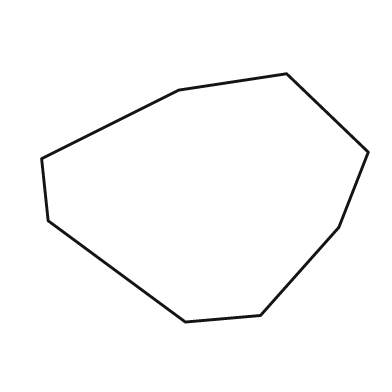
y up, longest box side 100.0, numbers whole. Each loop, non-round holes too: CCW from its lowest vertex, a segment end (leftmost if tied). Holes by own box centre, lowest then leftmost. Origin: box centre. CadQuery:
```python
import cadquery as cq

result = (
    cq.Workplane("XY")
    .moveTo(-6.0, -38.0)
    .lineTo(17.0, -36.0)
    .lineTo(41.0, -9.0)
    .lineTo(50.0, 14.0)
    .lineTo(25.0, 38.0)
    .lineTo(-8.0, 33.0)
    .lineTo(-50.0, 12.0)
    .lineTo(-48.0, -7.0)
    .close()
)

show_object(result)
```